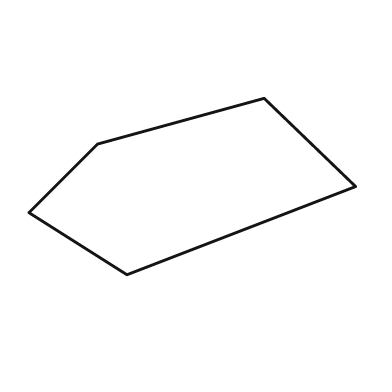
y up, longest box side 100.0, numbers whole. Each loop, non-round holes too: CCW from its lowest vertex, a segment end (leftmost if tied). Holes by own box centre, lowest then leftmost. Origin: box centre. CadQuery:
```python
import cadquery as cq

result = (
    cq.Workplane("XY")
    .moveTo(-20.0, -27.0)
    .lineTo(50.0, 0.0)
    .lineTo(22.0, 27.0)
    .lineTo(-29.0, 13.0)
    .lineTo(-50.0, -8.0)
    .close()
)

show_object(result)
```